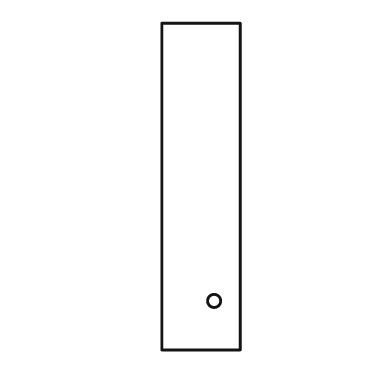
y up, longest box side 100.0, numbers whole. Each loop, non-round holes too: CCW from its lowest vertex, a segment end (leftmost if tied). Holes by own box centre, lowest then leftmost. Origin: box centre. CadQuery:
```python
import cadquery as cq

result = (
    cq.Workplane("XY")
    .moveTo(-12.0, -50.0)
    .lineTo(12.0, -50.0)
    .lineTo(12.0, 50.0)
    .lineTo(-12.0, 50.0)
    .close()
    .moveTo(4.0, -35.0)
    .circle(2.0)
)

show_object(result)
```